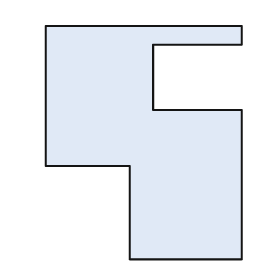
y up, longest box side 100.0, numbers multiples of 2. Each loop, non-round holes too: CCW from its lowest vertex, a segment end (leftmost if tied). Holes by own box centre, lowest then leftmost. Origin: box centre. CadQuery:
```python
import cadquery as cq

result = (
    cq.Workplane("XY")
    .moveTo(-6.0, -50.0)
    .lineTo(42.0, -50.0)
    .lineTo(42.0, 14.0)
    .lineTo(4.0, 14.0)
    .lineTo(4.0, 42.0)
    .lineTo(42.0, 42.0)
    .lineTo(42.0, 50.0)
    .lineTo(-42.0, 50.0)
    .lineTo(-42.0, -10.0)
    .lineTo(-6.0, -10.0)
    .close()
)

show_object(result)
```